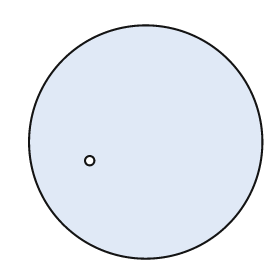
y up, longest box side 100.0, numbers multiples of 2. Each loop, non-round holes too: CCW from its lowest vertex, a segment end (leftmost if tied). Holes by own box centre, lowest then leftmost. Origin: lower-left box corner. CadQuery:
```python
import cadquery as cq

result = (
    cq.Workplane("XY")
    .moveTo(50.0, 50.0)
    .circle(50.0)
    .moveTo(26.0, 42.0)
    .circle(2.0)
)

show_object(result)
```